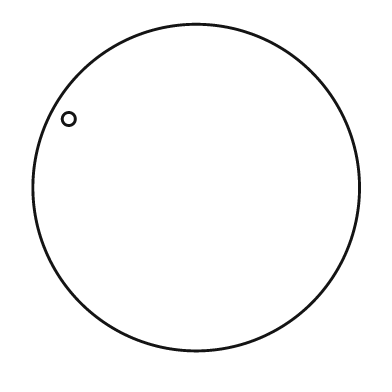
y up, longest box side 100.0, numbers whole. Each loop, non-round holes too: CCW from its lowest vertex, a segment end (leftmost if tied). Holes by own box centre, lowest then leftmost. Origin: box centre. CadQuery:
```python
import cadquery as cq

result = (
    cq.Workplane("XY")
    .moveTo(0.0, 0.0)
    .circle(50.0)
    .moveTo(-39.0, 21.0)
    .circle(2.0)
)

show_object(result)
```